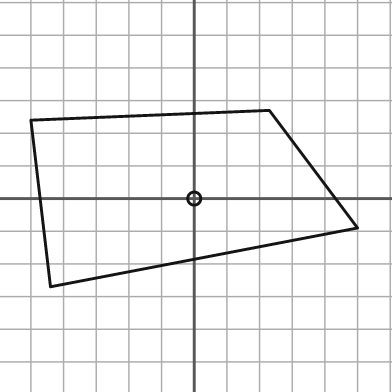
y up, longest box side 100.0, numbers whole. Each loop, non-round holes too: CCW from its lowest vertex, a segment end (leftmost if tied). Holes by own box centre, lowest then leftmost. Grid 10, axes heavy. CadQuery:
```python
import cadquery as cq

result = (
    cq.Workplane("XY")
    .moveTo(-44.0, -27.0)
    .lineTo(50.0, -9.0)
    .lineTo(23.0, 27.0)
    .lineTo(-50.0, 24.0)
    .close()
    .moveTo(0.0, 0.0)
    .circle(2.0)
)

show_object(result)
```